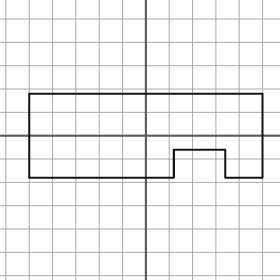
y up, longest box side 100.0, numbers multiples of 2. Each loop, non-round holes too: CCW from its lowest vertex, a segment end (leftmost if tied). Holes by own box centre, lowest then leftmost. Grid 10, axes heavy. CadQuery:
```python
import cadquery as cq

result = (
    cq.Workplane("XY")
    .moveTo(-50.0, -18.0)
    .lineTo(12.0, -18.0)
    .lineTo(12.0, -6.0)
    .lineTo(34.0, -6.0)
    .lineTo(34.0, -18.0)
    .lineTo(50.0, -18.0)
    .lineTo(50.0, 18.0)
    .lineTo(-50.0, 18.0)
    .close()
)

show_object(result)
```